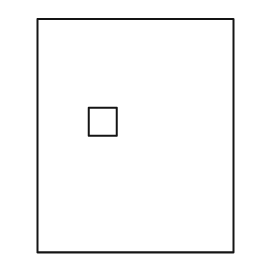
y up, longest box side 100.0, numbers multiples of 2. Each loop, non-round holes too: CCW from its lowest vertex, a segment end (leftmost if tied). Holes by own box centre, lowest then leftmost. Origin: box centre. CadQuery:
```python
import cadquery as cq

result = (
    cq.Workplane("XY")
    .moveTo(-42.0, -50.0)
    .lineTo(42.0, -50.0)
    .lineTo(42.0, 50.0)
    .lineTo(-42.0, 50.0)
    .close()
    .moveTo(-20.0, 0.0)
    .lineTo(-8.0, 0.0)
    .lineTo(-8.0, 12.0)
    .lineTo(-20.0, 12.0)
    .close()
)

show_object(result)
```